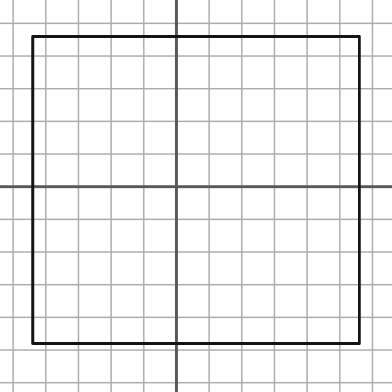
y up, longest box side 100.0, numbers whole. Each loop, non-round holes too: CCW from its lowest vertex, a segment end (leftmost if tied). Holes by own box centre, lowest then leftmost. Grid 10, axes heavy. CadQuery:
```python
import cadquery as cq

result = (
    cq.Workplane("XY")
    .moveTo(-44.0, -48.0)
    .lineTo(56.0, -48.0)
    .lineTo(56.0, 46.0)
    .lineTo(-44.0, 46.0)
    .close()
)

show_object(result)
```